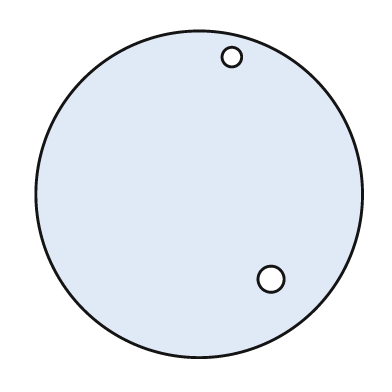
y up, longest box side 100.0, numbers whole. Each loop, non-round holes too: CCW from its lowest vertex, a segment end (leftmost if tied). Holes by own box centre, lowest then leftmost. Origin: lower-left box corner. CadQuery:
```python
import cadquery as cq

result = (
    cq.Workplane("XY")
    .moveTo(50.0, 50.0)
    .circle(50.0)
    .moveTo(72.0, 24.0)
    .circle(4.0)
    .moveTo(60.0, 92.0)
    .circle(3.0)
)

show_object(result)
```